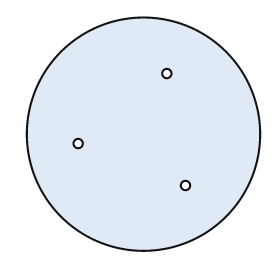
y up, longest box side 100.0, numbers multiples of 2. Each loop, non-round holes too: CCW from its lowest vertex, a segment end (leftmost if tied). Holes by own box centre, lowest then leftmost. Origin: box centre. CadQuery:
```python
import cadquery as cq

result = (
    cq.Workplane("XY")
    .moveTo(0.0, 0.0)
    .circle(50.0)
    .moveTo(18.0, -22.0)
    .circle(2.0)
    .moveTo(-28.0, -4.0)
    .circle(2.0)
    .moveTo(10.0, 26.0)
    .circle(2.0)
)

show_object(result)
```